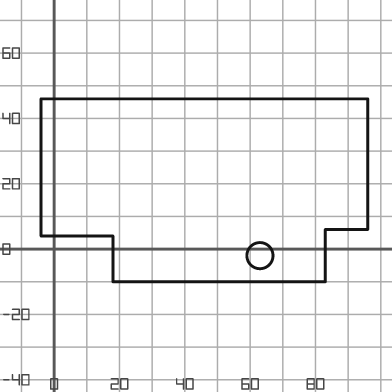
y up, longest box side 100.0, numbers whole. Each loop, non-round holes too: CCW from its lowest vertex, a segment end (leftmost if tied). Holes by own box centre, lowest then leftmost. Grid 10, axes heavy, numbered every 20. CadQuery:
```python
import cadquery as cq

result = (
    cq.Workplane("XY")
    .moveTo(18.0, -10.0)
    .lineTo(83.0, -10.0)
    .lineTo(83.0, 6.0)
    .lineTo(96.0, 6.0)
    .lineTo(96.0, 46.0)
    .lineTo(-4.0, 46.0)
    .lineTo(-4.0, 4.0)
    .lineTo(18.0, 4.0)
    .close()
    .moveTo(63.0, -2.0)
    .circle(4.0)
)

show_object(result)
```